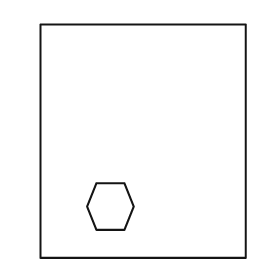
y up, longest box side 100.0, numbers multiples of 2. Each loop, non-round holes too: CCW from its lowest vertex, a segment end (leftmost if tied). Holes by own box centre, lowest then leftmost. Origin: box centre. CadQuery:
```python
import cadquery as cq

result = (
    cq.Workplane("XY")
    .moveTo(-44.0, -50.0)
    .lineTo(44.0, -50.0)
    .lineTo(44.0, 50.0)
    .lineTo(-44.0, 50.0)
    .close()
    .moveTo(-20.0, -38.0)
    .lineTo(-8.0, -38.0)
    .lineTo(-4.0, -28.0)
    .lineTo(-8.0, -18.0)
    .lineTo(-20.0, -18.0)
    .lineTo(-24.0, -28.0)
    .close()
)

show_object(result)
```